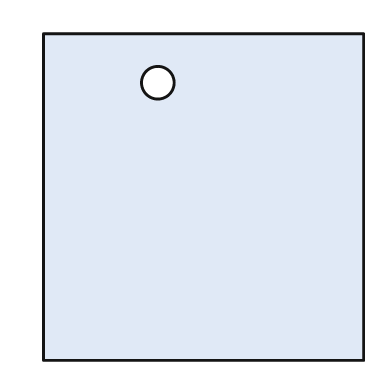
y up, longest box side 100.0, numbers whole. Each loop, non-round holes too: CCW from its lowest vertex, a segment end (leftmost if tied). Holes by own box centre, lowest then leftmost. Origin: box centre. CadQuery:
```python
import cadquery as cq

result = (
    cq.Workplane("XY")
    .moveTo(-49.0, -50.0)
    .lineTo(49.0, -50.0)
    .lineTo(49.0, 50.0)
    .lineTo(-49.0, 50.0)
    .close()
    .moveTo(-14.0, 35.0)
    .circle(5.0)
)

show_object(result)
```